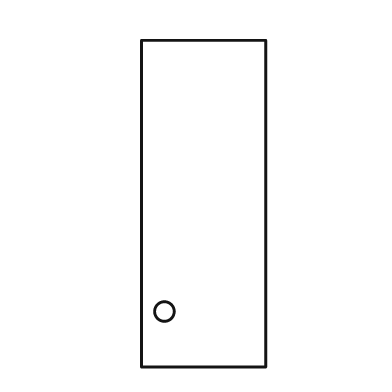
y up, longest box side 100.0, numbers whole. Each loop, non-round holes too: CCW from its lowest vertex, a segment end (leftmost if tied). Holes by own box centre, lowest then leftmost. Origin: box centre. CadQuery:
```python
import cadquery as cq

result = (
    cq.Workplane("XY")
    .moveTo(-19.0, -50.0)
    .lineTo(19.0, -50.0)
    .lineTo(19.0, 50.0)
    .lineTo(-19.0, 50.0)
    .close()
    .moveTo(-12.0, -33.0)
    .circle(3.0)
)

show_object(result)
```